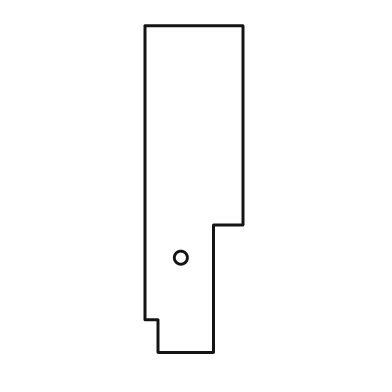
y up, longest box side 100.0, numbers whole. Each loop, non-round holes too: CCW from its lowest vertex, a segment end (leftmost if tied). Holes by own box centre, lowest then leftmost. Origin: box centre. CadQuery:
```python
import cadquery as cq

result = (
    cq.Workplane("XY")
    .moveTo(-11.0, -50.0)
    .lineTo(6.0, -50.0)
    .lineTo(6.0, -11.0)
    .lineTo(15.0, -11.0)
    .lineTo(15.0, 50.0)
    .lineTo(-15.0, 50.0)
    .lineTo(-15.0, -40.0)
    .lineTo(-11.0, -40.0)
    .close()
    .moveTo(-4.0, -21.0)
    .circle(2.0)
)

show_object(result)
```